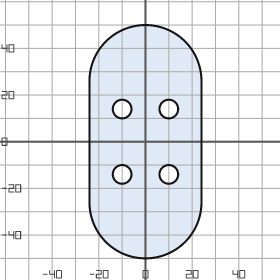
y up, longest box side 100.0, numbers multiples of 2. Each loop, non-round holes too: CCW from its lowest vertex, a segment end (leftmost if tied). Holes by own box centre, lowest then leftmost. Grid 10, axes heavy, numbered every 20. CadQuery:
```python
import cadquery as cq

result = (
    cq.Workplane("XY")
    .moveTo(-24.0, -26.0)
    .threePointArc((0.0, -50.0), (24.0, -26.0))
    .lineTo(24.0, 26.0)
    .threePointArc((0.0, 50.0), (-24.0, 26.0))
    .close()
    .moveTo(-10.0, -14.0)
    .circle(4.0)
    .moveTo(10.0, -14.0)
    .circle(4.0)
    .moveTo(-10.0, 14.0)
    .circle(4.0)
    .moveTo(10.0, 14.0)
    .circle(4.0)
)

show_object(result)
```